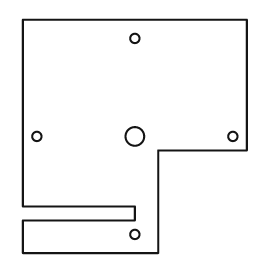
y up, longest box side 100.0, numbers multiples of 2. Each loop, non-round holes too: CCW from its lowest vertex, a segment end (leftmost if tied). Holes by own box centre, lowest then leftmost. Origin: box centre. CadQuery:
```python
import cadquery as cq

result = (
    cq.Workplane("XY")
    .moveTo(-48.0, -50.0)
    .lineTo(10.0, -50.0)
    .lineTo(10.0, -6.0)
    .lineTo(48.0, -6.0)
    .lineTo(48.0, 50.0)
    .lineTo(-48.0, 50.0)
    .lineTo(-48.0, -30.0)
    .lineTo(0.0, -30.0)
    .lineTo(0.0, -36.0)
    .lineTo(-48.0, -36.0)
    .close()
    .moveTo(0.0, -42.0)
    .circle(2.0)
    .moveTo(-42.0, 0.0)
    .circle(2.0)
    .moveTo(0.0, 0.0)
    .circle(4.0)
    .moveTo(42.0, 0.0)
    .circle(2.0)
    .moveTo(0.0, 42.0)
    .circle(2.0)
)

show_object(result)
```